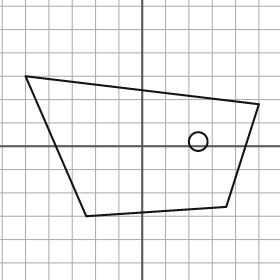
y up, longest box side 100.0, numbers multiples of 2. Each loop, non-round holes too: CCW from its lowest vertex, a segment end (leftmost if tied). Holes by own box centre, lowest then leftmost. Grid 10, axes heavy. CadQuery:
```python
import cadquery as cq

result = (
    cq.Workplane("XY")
    .moveTo(-24.0, -30.0)
    .lineTo(36.0, -26.0)
    .lineTo(50.0, 18.0)
    .lineTo(-50.0, 30.0)
    .close()
    .moveTo(24.0, 2.0)
    .circle(4.0)
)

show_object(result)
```